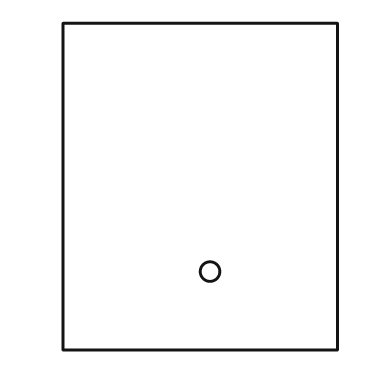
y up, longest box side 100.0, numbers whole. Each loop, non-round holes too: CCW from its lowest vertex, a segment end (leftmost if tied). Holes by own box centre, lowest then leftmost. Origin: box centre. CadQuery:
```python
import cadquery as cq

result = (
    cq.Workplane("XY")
    .moveTo(-42.0, -50.0)
    .lineTo(42.0, -50.0)
    .lineTo(42.0, 50.0)
    .lineTo(-42.0, 50.0)
    .close()
    .moveTo(3.0, -26.0)
    .circle(3.0)
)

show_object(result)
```